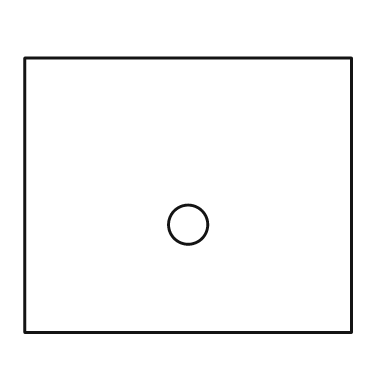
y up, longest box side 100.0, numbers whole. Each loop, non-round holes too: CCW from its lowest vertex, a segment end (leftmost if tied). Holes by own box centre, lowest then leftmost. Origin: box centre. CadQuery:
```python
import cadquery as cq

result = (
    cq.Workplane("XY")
    .moveTo(-50.0, -42.0)
    .lineTo(50.0, -42.0)
    .lineTo(50.0, 42.0)
    .lineTo(-50.0, 42.0)
    .close()
    .moveTo(0.0, -9.0)
    .circle(6.0)
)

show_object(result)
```